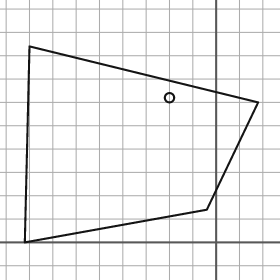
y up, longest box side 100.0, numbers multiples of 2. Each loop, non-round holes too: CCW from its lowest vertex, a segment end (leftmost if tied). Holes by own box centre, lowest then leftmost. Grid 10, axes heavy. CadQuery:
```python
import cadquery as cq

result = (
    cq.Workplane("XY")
    .moveTo(-82.0, 0.0)
    .lineTo(-4.0, 14.0)
    .lineTo(18.0, 60.0)
    .lineTo(-80.0, 84.0)
    .close()
    .moveTo(-20.0, 62.0)
    .circle(2.0)
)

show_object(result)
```